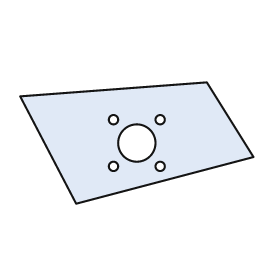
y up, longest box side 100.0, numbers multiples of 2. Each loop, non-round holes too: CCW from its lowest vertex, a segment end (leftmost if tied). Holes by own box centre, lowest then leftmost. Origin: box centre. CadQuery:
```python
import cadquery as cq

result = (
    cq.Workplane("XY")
    .moveTo(-26.0, -26.0)
    .lineTo(50.0, -6.0)
    .lineTo(30.0, 26.0)
    .lineTo(-50.0, 20.0)
    .close()
    .moveTo(-10.0, -10.0)
    .circle(2.0)
    .moveTo(10.0, -10.0)
    .circle(2.0)
    .moveTo(0.0, 0.0)
    .circle(8.0)
    .moveTo(-10.0, 10.0)
    .circle(2.0)
    .moveTo(10.0, 10.0)
    .circle(2.0)
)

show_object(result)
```